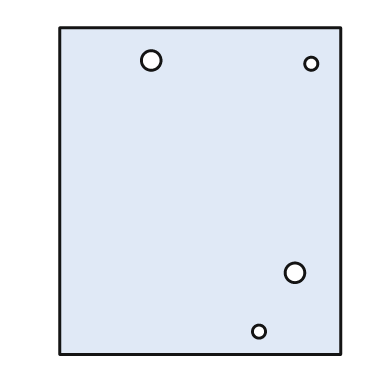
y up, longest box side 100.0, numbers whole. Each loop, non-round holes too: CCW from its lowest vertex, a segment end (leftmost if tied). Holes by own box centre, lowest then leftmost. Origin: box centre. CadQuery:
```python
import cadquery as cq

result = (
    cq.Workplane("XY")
    .moveTo(-43.0, -50.0)
    .lineTo(43.0, -50.0)
    .lineTo(43.0, 50.0)
    .lineTo(-43.0, 50.0)
    .close()
    .moveTo(18.0, -43.0)
    .circle(2.0)
    .moveTo(29.0, -25.0)
    .circle(3.0)
    .moveTo(34.0, 39.0)
    .circle(2.0)
    .moveTo(-15.0, 40.0)
    .circle(3.0)
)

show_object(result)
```